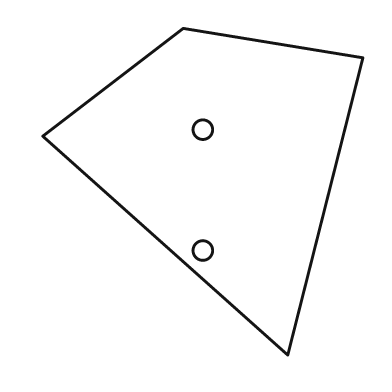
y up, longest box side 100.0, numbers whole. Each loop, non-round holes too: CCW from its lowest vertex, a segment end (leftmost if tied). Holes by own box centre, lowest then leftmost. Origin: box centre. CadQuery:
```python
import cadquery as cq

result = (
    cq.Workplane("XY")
    .moveTo(26.0, -50.0)
    .lineTo(49.0, 41.0)
    .lineTo(-6.0, 50.0)
    .lineTo(-49.0, 17.0)
    .close()
    .moveTo(0.0, -18.0)
    .circle(3.0)
    .moveTo(0.0, 19.0)
    .circle(3.0)
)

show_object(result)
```